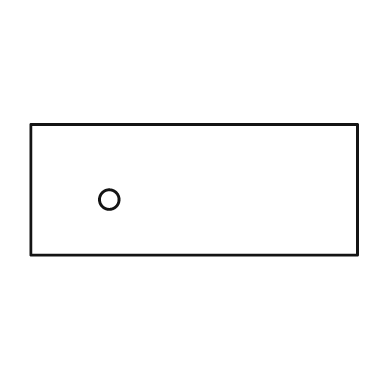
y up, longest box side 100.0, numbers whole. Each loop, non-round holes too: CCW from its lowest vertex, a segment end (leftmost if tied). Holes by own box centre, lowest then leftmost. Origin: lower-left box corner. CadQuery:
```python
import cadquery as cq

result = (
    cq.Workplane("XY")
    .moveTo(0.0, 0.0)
    .lineTo(100.0, 0.0)
    .lineTo(100.0, 40.0)
    .lineTo(0.0, 40.0)
    .close()
    .moveTo(24.0, 17.0)
    .circle(3.0)
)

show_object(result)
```